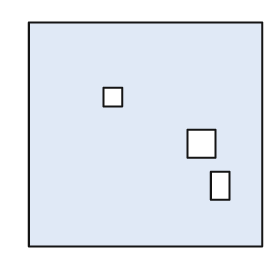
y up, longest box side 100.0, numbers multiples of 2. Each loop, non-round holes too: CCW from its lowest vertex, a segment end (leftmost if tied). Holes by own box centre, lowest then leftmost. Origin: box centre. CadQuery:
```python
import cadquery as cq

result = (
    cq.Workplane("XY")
    .moveTo(-50.0, -48.0)
    .lineTo(50.0, -48.0)
    .lineTo(50.0, 48.0)
    .lineTo(-50.0, 48.0)
    .close()
    .moveTo(28.0, -28.0)
    .lineTo(36.0, -28.0)
    .lineTo(36.0, -16.0)
    .lineTo(28.0, -16.0)
    .close()
    .moveTo(18.0, -10.0)
    .lineTo(30.0, -10.0)
    .lineTo(30.0, 2.0)
    .lineTo(18.0, 2.0)
    .close()
    .moveTo(-18.0, 12.0)
    .lineTo(-10.0, 12.0)
    .lineTo(-10.0, 20.0)
    .lineTo(-18.0, 20.0)
    .close()
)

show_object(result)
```